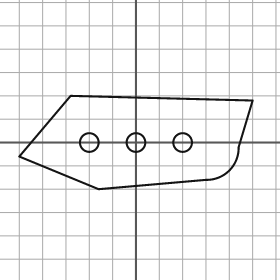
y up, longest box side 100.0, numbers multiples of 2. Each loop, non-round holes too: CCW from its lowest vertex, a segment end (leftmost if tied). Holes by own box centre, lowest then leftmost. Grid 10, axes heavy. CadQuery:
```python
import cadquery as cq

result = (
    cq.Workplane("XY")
    .moveTo(-16.0, -20.0)
    .lineTo(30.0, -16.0)
    .threePointArc((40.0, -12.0), (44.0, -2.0))
    .lineTo(50.0, 18.0)
    .lineTo(-28.0, 20.0)
    .lineTo(-50.0, -6.0)
    .close()
    .moveTo(-20.0, 0.0)
    .circle(4.0)
    .moveTo(0.0, 0.0)
    .circle(4.0)
    .moveTo(20.0, 0.0)
    .circle(4.0)
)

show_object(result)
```